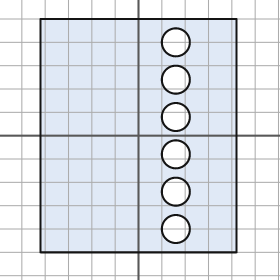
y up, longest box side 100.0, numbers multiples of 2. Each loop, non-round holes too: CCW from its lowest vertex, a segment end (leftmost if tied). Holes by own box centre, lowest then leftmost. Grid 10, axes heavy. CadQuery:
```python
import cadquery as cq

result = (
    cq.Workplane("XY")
    .moveTo(-42.0, -50.0)
    .lineTo(42.0, -50.0)
    .lineTo(42.0, 50.0)
    .lineTo(-42.0, 50.0)
    .close()
    .moveTo(16.0, -40.0)
    .circle(6.0)
    .moveTo(16.0, -24.0)
    .circle(6.0)
    .moveTo(16.0, -8.0)
    .circle(6.0)
    .moveTo(16.0, 8.0)
    .circle(6.0)
    .moveTo(16.0, 24.0)
    .circle(6.0)
    .moveTo(16.0, 40.0)
    .circle(6.0)
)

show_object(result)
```